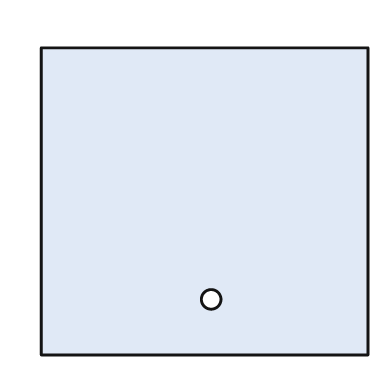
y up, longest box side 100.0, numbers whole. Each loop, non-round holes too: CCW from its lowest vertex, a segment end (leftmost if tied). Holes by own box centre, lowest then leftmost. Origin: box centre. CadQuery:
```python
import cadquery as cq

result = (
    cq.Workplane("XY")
    .moveTo(-50.0, -47.0)
    .lineTo(50.0, -47.0)
    .lineTo(50.0, 47.0)
    .lineTo(-50.0, 47.0)
    .close()
    .moveTo(2.0, -30.0)
    .circle(3.0)
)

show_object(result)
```